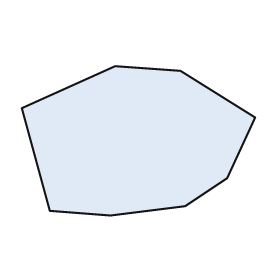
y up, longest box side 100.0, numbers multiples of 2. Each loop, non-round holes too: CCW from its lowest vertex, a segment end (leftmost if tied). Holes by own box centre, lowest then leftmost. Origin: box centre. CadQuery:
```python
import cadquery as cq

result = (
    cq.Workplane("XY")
    .moveTo(-12.0, -32.0)
    .lineTo(20.0, -28.0)
    .lineTo(38.0, -16.0)
    .lineTo(50.0, 10.0)
    .lineTo(18.0, 30.0)
    .lineTo(-10.0, 32.0)
    .lineTo(-50.0, 14.0)
    .lineTo(-38.0, -30.0)
    .close()
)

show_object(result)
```